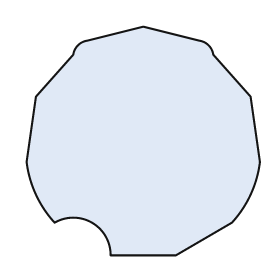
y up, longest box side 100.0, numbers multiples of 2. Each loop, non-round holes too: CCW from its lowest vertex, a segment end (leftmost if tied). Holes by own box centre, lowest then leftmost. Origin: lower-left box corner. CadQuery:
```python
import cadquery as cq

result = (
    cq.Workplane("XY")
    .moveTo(36.0, 0.0)
    .lineTo(64.0, 0.0)
    .lineTo(88.0, 14.0)
    .threePointArc((96.0, 26.0), (100.0, 40.0))
    .lineTo(96.0, 68.0)
    .lineTo(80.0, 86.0)
    .threePointArc((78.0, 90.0), (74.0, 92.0))
    .lineTo(50.0, 98.0)
    .lineTo(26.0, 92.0)
    .threePointArc((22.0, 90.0), (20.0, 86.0))
    .lineTo(4.0, 68.0)
    .lineTo(0.0, 40.0)
    .threePointArc((4.0, 26.0), (12.0, 14.0))
    .threePointArc((28.0, 14.0), (36.0, 0.0))
    .close()
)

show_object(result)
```